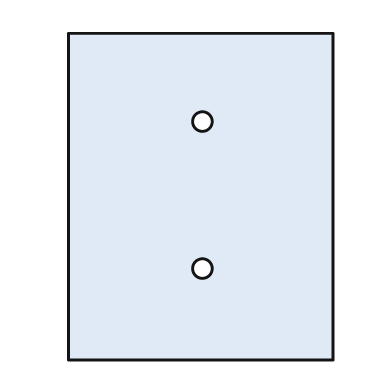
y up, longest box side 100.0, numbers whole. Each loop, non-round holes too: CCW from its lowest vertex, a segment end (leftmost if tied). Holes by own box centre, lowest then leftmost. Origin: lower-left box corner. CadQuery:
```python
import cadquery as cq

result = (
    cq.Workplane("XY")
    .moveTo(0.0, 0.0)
    .lineTo(81.0, 0.0)
    .lineTo(81.0, 100.0)
    .lineTo(0.0, 100.0)
    .close()
    .moveTo(41.0, 28.0)
    .circle(3.0)
    .moveTo(41.0, 73.0)
    .circle(3.0)
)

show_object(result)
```